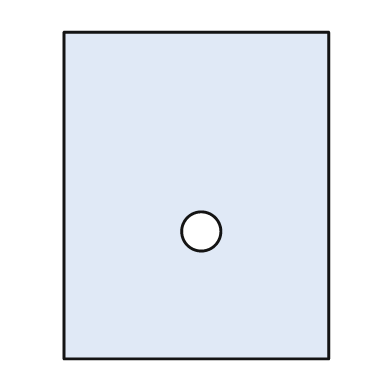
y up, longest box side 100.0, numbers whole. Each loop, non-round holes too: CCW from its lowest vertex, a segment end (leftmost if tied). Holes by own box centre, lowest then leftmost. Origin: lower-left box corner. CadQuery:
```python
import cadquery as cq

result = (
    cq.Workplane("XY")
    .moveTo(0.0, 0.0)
    .lineTo(81.0, 0.0)
    .lineTo(81.0, 100.0)
    .lineTo(0.0, 100.0)
    .close()
    .moveTo(42.0, 39.0)
    .circle(6.0)
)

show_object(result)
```